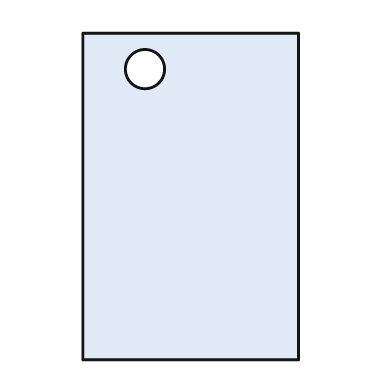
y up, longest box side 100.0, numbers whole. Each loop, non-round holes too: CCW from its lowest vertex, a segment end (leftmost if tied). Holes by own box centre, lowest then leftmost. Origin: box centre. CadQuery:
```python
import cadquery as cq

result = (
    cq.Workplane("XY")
    .moveTo(-33.0, -50.0)
    .lineTo(33.0, -50.0)
    .lineTo(33.0, 50.0)
    .lineTo(-33.0, 50.0)
    .close()
    .moveTo(-14.0, 39.0)
    .circle(6.0)
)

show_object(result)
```